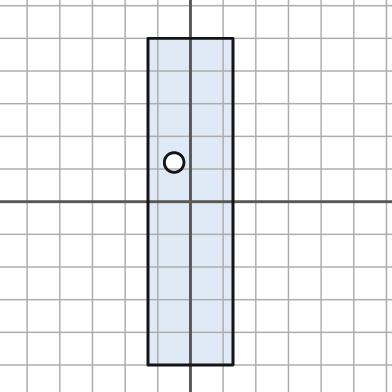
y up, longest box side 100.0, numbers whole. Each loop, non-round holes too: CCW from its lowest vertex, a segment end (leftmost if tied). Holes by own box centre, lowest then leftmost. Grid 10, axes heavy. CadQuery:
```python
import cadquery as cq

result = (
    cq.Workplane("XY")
    .moveTo(-13.0, -50.0)
    .lineTo(13.0, -50.0)
    .lineTo(13.0, 50.0)
    .lineTo(-13.0, 50.0)
    .close()
    .moveTo(-5.0, 12.0)
    .circle(3.0)
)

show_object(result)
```